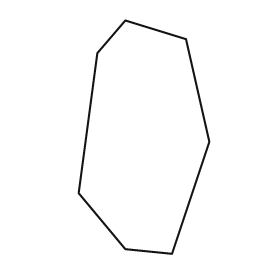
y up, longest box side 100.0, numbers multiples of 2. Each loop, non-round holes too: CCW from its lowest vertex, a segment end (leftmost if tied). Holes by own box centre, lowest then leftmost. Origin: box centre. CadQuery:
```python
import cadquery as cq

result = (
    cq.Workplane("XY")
    .moveTo(12.0, -50.0)
    .lineTo(28.0, -2.0)
    .lineTo(18.0, 42.0)
    .lineTo(-8.0, 50.0)
    .lineTo(-20.0, 36.0)
    .lineTo(-28.0, -24.0)
    .lineTo(-8.0, -48.0)
    .close()
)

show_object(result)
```